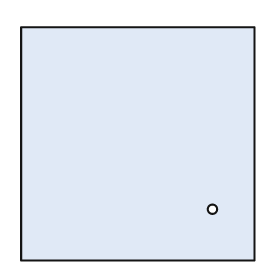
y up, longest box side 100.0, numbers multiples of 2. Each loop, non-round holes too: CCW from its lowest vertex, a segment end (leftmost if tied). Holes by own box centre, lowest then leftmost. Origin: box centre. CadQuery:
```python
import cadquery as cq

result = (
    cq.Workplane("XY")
    .moveTo(-50.0, -50.0)
    .lineTo(50.0, -50.0)
    .lineTo(50.0, 50.0)
    .lineTo(-50.0, 50.0)
    .close()
    .moveTo(32.0, -28.0)
    .circle(2.0)
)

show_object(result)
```